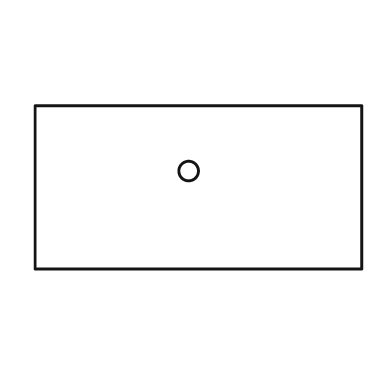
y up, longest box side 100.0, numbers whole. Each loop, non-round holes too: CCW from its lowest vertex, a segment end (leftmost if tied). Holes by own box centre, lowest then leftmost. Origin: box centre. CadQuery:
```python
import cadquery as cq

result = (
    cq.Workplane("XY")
    .moveTo(-50.0, -25.0)
    .lineTo(50.0, -25.0)
    .lineTo(50.0, 25.0)
    .lineTo(-50.0, 25.0)
    .close()
    .moveTo(-3.0, 5.0)
    .circle(3.0)
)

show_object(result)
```